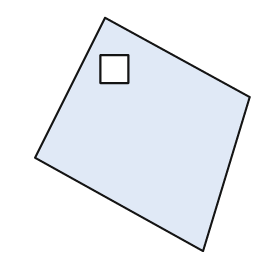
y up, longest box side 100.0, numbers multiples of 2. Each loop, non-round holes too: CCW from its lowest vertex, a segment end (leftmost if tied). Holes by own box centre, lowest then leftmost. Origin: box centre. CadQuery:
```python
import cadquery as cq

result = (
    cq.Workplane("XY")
    .moveTo(26.0, -50.0)
    .lineTo(46.0, 16.0)
    .lineTo(-16.0, 50.0)
    .lineTo(-46.0, -10.0)
    .close()
    .moveTo(-18.0, 22.0)
    .lineTo(-6.0, 22.0)
    .lineTo(-6.0, 34.0)
    .lineTo(-18.0, 34.0)
    .close()
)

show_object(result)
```